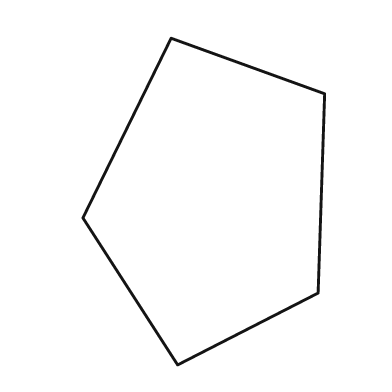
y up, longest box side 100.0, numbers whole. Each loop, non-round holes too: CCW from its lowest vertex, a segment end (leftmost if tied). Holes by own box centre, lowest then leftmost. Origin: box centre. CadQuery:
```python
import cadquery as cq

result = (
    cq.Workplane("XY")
    .moveTo(-8.0, -50.0)
    .lineTo(35.0, -28.0)
    .lineTo(37.0, 33.0)
    .lineTo(-10.0, 50.0)
    .lineTo(-37.0, -5.0)
    .close()
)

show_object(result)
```